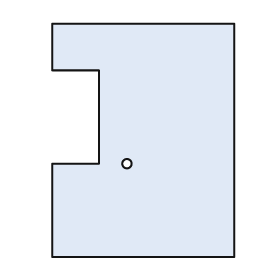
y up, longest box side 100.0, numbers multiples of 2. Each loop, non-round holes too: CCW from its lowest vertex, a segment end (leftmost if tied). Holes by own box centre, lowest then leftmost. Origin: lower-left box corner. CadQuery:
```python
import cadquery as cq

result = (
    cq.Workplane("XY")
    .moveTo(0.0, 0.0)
    .lineTo(78.0, 0.0)
    .lineTo(78.0, 100.0)
    .lineTo(0.0, 100.0)
    .lineTo(0.0, 80.0)
    .lineTo(20.0, 80.0)
    .lineTo(20.0, 40.0)
    .lineTo(0.0, 40.0)
    .close()
    .moveTo(32.0, 40.0)
    .circle(2.0)
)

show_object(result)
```